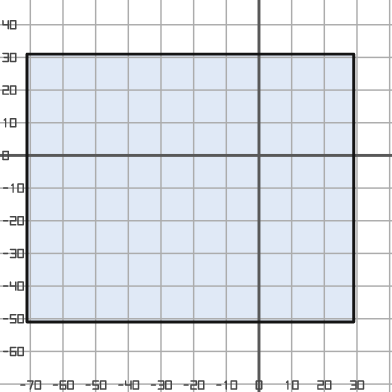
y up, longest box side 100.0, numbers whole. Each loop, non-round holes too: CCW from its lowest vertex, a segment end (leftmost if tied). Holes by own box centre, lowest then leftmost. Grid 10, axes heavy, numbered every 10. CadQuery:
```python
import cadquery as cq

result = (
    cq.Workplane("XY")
    .moveTo(-71.0, -51.0)
    .lineTo(29.0, -51.0)
    .lineTo(29.0, 31.0)
    .lineTo(-71.0, 31.0)
    .close()
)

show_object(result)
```